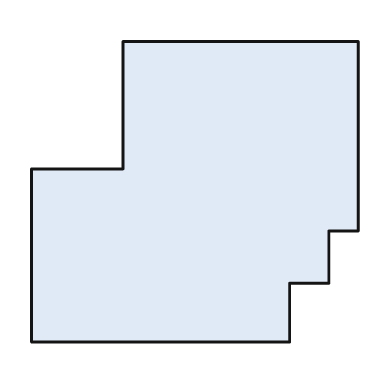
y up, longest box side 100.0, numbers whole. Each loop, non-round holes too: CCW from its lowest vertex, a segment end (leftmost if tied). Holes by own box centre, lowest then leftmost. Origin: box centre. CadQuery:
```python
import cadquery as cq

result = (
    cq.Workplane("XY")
    .moveTo(-50.0, -46.0)
    .lineTo(29.0, -46.0)
    .lineTo(29.0, -28.0)
    .lineTo(41.0, -28.0)
    .lineTo(41.0, -12.0)
    .lineTo(50.0, -12.0)
    .lineTo(50.0, 46.0)
    .lineTo(-22.0, 46.0)
    .lineTo(-22.0, 7.0)
    .lineTo(-50.0, 7.0)
    .close()
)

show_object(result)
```